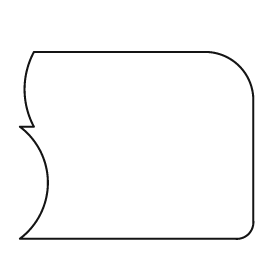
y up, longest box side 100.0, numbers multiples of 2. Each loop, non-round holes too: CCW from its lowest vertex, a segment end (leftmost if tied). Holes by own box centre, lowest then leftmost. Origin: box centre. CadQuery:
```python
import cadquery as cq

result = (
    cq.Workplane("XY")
    .moveTo(-50.0, -40.0)
    .lineTo(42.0, -40.0)
    .threePointArc((48.0, -38.0), (50.0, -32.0))
    .lineTo(50.0, 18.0)
    .threePointArc((44.0, 34.0), (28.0, 40.0))
    .lineTo(-44.0, 40.0)
    .threePointArc((-48.0, 24.0), (-44.0, 8.0))
    .lineTo(-50.0, 8.0)
    .threePointArc((-38.0, -16.0), (-50.0, -40.0))
    .close()
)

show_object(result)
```